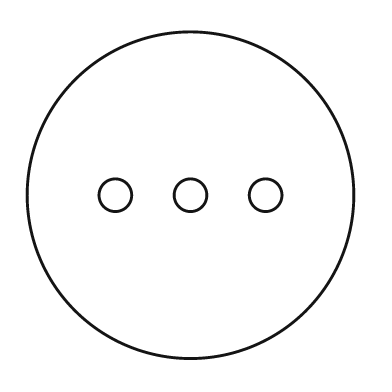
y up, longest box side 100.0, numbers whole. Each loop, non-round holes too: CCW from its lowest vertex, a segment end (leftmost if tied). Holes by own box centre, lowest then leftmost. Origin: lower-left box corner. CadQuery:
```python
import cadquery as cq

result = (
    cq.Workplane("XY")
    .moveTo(50.0, 50.0)
    .circle(50.0)
    .moveTo(27.0, 50.0)
    .circle(5.0)
    .moveTo(50.0, 50.0)
    .circle(5.0)
    .moveTo(73.0, 50.0)
    .circle(5.0)
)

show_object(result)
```